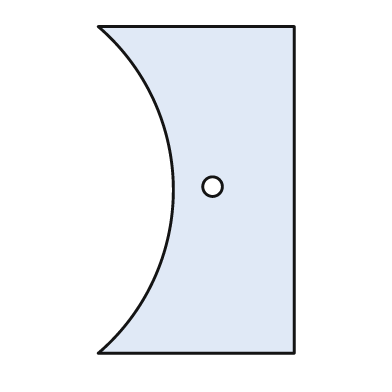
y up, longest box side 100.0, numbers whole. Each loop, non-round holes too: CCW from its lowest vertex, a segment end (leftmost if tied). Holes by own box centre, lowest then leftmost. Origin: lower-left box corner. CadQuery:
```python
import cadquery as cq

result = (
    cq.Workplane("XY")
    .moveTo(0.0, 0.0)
    .lineTo(60.0, 0.0)
    .lineTo(60.0, 100.0)
    .lineTo(0.0, 100.0)
    .threePointArc((23.0, 50.0), (0.0, 0.0))
    .close()
    .moveTo(35.0, 51.0)
    .circle(3.0)
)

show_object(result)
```